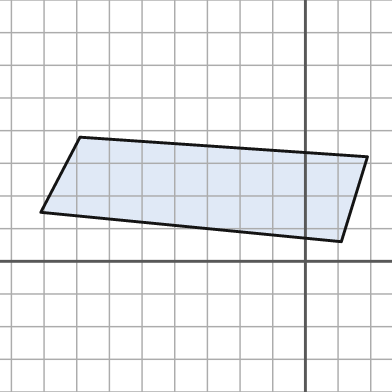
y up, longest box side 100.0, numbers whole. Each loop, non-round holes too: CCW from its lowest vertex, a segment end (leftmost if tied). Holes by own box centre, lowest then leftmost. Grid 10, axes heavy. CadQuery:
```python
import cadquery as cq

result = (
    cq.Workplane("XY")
    .moveTo(11.0, 6.0)
    .lineTo(19.0, 32.0)
    .lineTo(-69.0, 38.0)
    .lineTo(-81.0, 15.0)
    .close()
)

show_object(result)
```